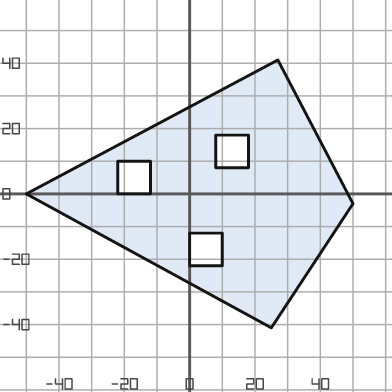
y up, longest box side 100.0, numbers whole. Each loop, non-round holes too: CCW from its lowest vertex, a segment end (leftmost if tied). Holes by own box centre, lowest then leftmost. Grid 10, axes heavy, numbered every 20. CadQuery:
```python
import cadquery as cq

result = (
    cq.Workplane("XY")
    .moveTo(25.0, -41.0)
    .lineTo(50.0, -3.0)
    .lineTo(27.0, 41.0)
    .lineTo(-50.0, 0.0)
    .close()
    .moveTo(0.0, -22.0)
    .lineTo(10.0, -22.0)
    .lineTo(10.0, -12.0)
    .lineTo(0.0, -12.0)
    .close()
    .moveTo(-22.0, 0.0)
    .lineTo(-12.0, 0.0)
    .lineTo(-12.0, 10.0)
    .lineTo(-22.0, 10.0)
    .close()
    .moveTo(8.0, 8.0)
    .lineTo(18.0, 8.0)
    .lineTo(18.0, 18.0)
    .lineTo(8.0, 18.0)
    .close()
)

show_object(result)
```